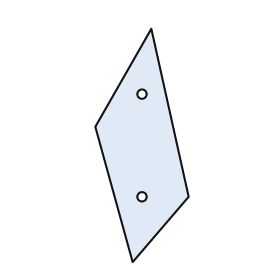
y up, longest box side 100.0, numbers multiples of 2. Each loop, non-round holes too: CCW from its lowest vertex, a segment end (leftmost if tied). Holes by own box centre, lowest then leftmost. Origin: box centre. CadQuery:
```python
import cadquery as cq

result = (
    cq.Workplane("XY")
    .moveTo(-4.0, -50.0)
    .lineTo(20.0, -22.0)
    .lineTo(4.0, 50.0)
    .lineTo(-20.0, 8.0)
    .close()
    .moveTo(0.0, -22.0)
    .circle(2.0)
    .moveTo(0.0, 22.0)
    .circle(2.0)
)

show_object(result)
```